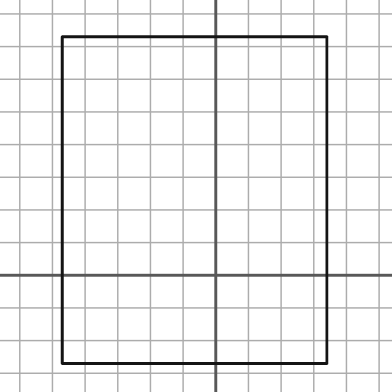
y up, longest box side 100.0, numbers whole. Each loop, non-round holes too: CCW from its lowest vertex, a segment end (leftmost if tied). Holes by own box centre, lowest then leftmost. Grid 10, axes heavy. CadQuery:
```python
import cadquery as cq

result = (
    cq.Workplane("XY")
    .moveTo(-47.0, -27.0)
    .lineTo(34.0, -27.0)
    .lineTo(34.0, 73.0)
    .lineTo(-47.0, 73.0)
    .close()
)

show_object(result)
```